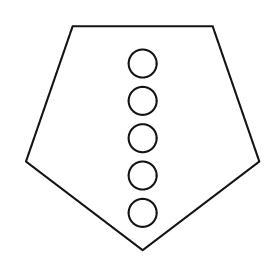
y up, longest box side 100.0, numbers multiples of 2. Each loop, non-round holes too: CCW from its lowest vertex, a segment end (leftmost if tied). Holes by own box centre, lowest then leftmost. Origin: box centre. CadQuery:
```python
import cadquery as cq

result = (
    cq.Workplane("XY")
    .moveTo(0.0, -48.0)
    .lineTo(50.0, -10.0)
    .lineTo(30.0, 48.0)
    .lineTo(-30.0, 48.0)
    .lineTo(-50.0, -10.0)
    .close()
    .moveTo(0.0, -32.0)
    .circle(6.0)
    .moveTo(0.0, -16.0)
    .circle(6.0)
    .moveTo(0.0, 0.0)
    .circle(6.0)
    .moveTo(0.0, 16.0)
    .circle(6.0)
    .moveTo(0.0, 32.0)
    .circle(6.0)
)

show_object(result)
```